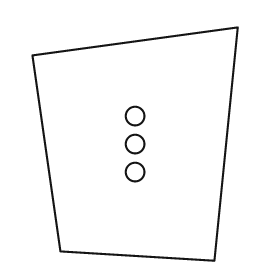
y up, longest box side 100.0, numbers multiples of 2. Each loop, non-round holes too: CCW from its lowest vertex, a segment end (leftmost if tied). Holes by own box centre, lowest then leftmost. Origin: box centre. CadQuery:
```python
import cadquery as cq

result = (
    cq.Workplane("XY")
    .moveTo(34.0, -50.0)
    .lineTo(44.0, 50.0)
    .lineTo(-44.0, 38.0)
    .lineTo(-32.0, -46.0)
    .close()
    .moveTo(0.0, -12.0)
    .circle(4.0)
    .moveTo(0.0, 0.0)
    .circle(4.0)
    .moveTo(0.0, 12.0)
    .circle(4.0)
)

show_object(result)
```